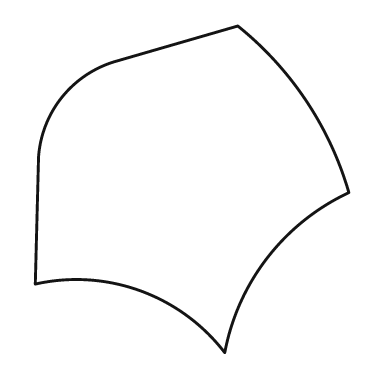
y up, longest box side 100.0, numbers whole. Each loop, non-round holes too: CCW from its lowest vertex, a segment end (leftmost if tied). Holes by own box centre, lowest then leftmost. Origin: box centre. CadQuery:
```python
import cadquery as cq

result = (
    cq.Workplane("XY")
    .moveTo(10.0, -50.0)
    .threePointArc((23.0, -21.0), (48.0, -1.0))
    .threePointArc((35.0, 27.0), (14.0, 50.0))
    .lineTo(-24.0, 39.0)
    .threePointArc((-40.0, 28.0), (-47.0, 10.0))
    .lineTo(-48.0, -29.0)
    .threePointArc((-16.0, -31.0), (10.0, -50.0))
    .close()
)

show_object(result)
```